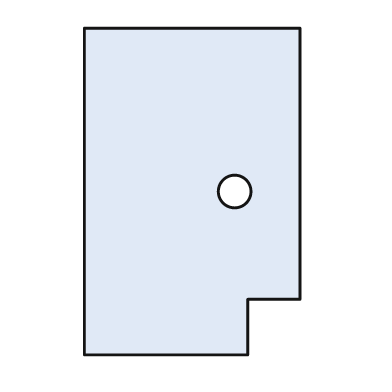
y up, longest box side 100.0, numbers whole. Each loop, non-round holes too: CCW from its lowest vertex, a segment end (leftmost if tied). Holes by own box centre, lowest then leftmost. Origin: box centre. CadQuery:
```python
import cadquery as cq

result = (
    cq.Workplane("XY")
    .moveTo(-33.0, -50.0)
    .lineTo(17.0, -50.0)
    .lineTo(17.0, -33.0)
    .lineTo(33.0, -33.0)
    .lineTo(33.0, 50.0)
    .lineTo(-33.0, 50.0)
    .close()
    .moveTo(13.0, 0.0)
    .circle(5.0)
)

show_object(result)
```